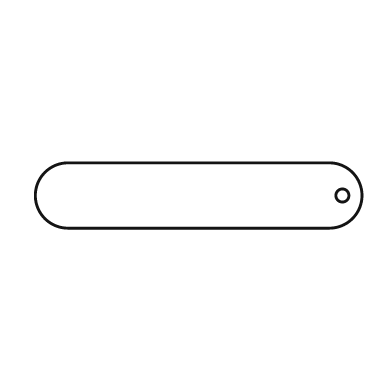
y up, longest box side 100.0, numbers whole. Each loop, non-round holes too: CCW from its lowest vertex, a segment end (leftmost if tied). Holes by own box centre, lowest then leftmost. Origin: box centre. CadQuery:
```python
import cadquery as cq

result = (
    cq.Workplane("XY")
    .moveTo(-40.0, -10.0)
    .lineTo(40.0, -10.0)
    .threePointArc((50.0, 0.0), (40.0, 10.0))
    .lineTo(-40.0, 10.0)
    .threePointArc((-50.0, 0.0), (-40.0, -10.0))
    .close()
    .moveTo(44.0, 0.0)
    .circle(2.0)
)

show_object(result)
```